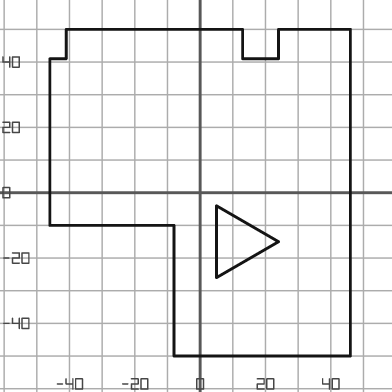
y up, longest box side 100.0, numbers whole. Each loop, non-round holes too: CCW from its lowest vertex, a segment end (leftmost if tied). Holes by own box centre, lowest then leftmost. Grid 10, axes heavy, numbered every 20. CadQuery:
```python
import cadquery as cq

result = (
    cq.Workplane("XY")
    .moveTo(-8.0, -50.0)
    .lineTo(46.0, -50.0)
    .lineTo(46.0, 50.0)
    .lineTo(24.0, 50.0)
    .lineTo(24.0, 41.0)
    .lineTo(13.0, 41.0)
    .lineTo(13.0, 50.0)
    .lineTo(-41.0, 50.0)
    .lineTo(-41.0, 41.0)
    .lineTo(-46.0, 41.0)
    .lineTo(-46.0, -10.0)
    .lineTo(-8.0, -10.0)
    .close()
    .moveTo(5.0, -26.0)
    .lineTo(24.0, -15.0)
    .lineTo(5.0, -4.0)
    .close()
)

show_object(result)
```